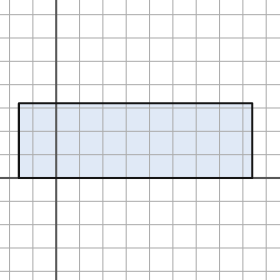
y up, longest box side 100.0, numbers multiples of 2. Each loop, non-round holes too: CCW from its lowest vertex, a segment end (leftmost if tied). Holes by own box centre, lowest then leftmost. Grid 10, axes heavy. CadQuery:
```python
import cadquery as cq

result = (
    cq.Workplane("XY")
    .moveTo(-16.0, 0.0)
    .lineTo(84.0, 0.0)
    .lineTo(84.0, 32.0)
    .lineTo(-16.0, 32.0)
    .close()
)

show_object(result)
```